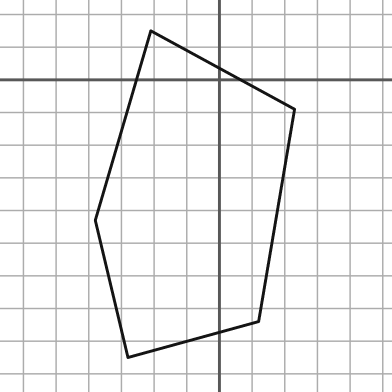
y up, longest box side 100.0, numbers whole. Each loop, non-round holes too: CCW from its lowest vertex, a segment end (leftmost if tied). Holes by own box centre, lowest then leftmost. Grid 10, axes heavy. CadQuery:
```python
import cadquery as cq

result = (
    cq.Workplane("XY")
    .moveTo(-28.0, -85.0)
    .lineTo(12.0, -74.0)
    .lineTo(23.0, -9.0)
    .lineTo(-21.0, 15.0)
    .lineTo(-38.0, -43.0)
    .close()
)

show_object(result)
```